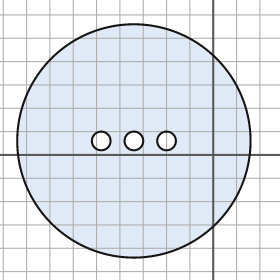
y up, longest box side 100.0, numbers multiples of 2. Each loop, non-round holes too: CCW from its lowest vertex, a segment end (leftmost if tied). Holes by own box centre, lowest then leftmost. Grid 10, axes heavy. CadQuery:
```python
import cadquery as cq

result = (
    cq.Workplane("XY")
    .moveTo(-34.0, 6.0)
    .circle(50.0)
    .moveTo(-48.0, 6.0)
    .circle(4.0)
    .moveTo(-34.0, 6.0)
    .circle(4.0)
    .moveTo(-20.0, 6.0)
    .circle(4.0)
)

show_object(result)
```